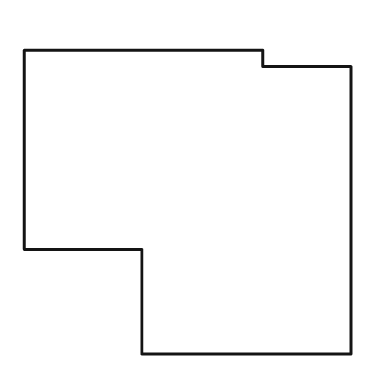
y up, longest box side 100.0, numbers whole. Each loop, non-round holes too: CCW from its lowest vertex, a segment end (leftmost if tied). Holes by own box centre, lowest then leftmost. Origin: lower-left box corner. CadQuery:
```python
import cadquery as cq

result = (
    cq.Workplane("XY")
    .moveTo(36.0, 0.0)
    .lineTo(100.0, 0.0)
    .lineTo(100.0, 88.0)
    .lineTo(73.0, 88.0)
    .lineTo(73.0, 93.0)
    .lineTo(0.0, 93.0)
    .lineTo(0.0, 32.0)
    .lineTo(36.0, 32.0)
    .close()
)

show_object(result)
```